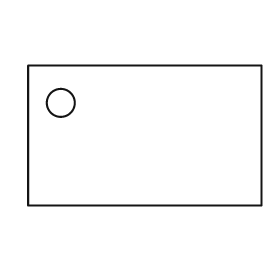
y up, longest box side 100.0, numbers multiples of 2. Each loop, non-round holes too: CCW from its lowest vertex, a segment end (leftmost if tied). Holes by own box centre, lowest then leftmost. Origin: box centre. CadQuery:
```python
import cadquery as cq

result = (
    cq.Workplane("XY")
    .moveTo(-50.0, -30.0)
    .lineTo(50.0, -30.0)
    .lineTo(50.0, 30.0)
    .lineTo(-50.0, 30.0)
    .close()
    .moveTo(-36.0, 14.0)
    .circle(6.0)
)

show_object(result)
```